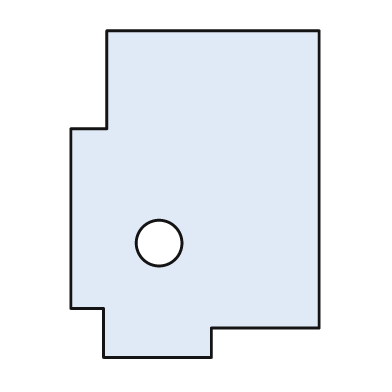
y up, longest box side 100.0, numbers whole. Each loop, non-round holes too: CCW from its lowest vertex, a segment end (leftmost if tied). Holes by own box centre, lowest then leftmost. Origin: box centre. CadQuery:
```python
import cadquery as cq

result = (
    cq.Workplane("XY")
    .moveTo(-28.0, -50.0)
    .lineTo(5.0, -50.0)
    .lineTo(5.0, -41.0)
    .lineTo(38.0, -41.0)
    .lineTo(38.0, 50.0)
    .lineTo(-27.0, 50.0)
    .lineTo(-27.0, 20.0)
    .lineTo(-38.0, 20.0)
    .lineTo(-38.0, -35.0)
    .lineTo(-28.0, -35.0)
    .close()
    .moveTo(-11.0, -15.0)
    .circle(7.0)
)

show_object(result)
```